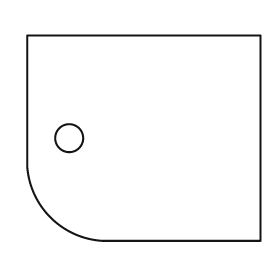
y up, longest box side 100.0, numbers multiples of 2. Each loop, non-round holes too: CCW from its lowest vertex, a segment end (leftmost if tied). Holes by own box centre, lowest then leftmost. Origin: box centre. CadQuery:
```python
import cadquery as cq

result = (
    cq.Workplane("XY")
    .moveTo(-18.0, -44.0)
    .lineTo(50.0, -44.0)
    .lineTo(50.0, 44.0)
    .lineTo(-50.0, 44.0)
    .lineTo(-50.0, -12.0)
    .threePointArc((-40.0, -34.0), (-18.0, -44.0))
    .close()
    .moveTo(-32.0, 0.0)
    .circle(6.0)
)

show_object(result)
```